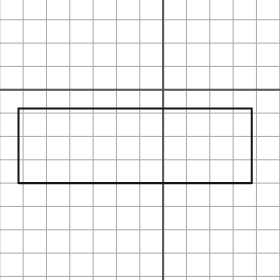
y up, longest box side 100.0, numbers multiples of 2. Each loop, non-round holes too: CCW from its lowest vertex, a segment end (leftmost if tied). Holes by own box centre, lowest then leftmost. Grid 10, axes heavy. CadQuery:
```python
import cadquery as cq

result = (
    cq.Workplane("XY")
    .moveTo(-62.0, -40.0)
    .lineTo(38.0, -40.0)
    .lineTo(38.0, -8.0)
    .lineTo(-62.0, -8.0)
    .close()
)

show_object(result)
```